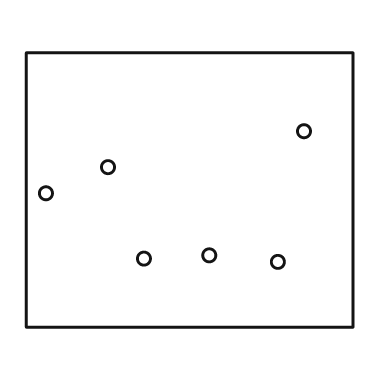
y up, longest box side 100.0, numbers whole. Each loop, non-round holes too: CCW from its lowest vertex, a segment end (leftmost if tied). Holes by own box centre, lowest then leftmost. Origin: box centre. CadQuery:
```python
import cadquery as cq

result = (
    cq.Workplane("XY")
    .moveTo(-50.0, -42.0)
    .lineTo(50.0, -42.0)
    .lineTo(50.0, 42.0)
    .lineTo(-50.0, 42.0)
    .close()
    .moveTo(27.0, -22.0)
    .circle(2.0)
    .moveTo(-14.0, -21.0)
    .circle(2.0)
    .moveTo(6.0, -20.0)
    .circle(2.0)
    .moveTo(-44.0, -1.0)
    .circle(2.0)
    .moveTo(-25.0, 7.0)
    .circle(2.0)
    .moveTo(35.0, 18.0)
    .circle(2.0)
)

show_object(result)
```